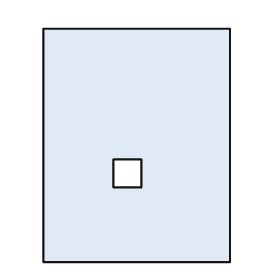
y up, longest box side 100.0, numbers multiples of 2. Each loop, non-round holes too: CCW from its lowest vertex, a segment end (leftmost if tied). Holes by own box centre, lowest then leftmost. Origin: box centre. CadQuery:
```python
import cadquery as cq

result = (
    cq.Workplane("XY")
    .moveTo(-40.0, -50.0)
    .lineTo(40.0, -50.0)
    .lineTo(40.0, 50.0)
    .lineTo(-40.0, 50.0)
    .close()
    .moveTo(-10.0, -18.0)
    .lineTo(2.0, -18.0)
    .lineTo(2.0, -6.0)
    .lineTo(-10.0, -6.0)
    .close()
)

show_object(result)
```